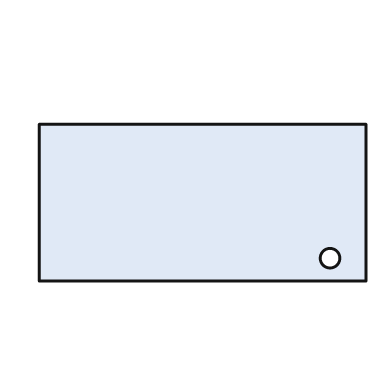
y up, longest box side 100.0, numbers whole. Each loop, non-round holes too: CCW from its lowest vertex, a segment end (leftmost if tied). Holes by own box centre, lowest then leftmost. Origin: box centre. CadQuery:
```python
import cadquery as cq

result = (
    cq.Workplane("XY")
    .moveTo(-50.0, -24.0)
    .lineTo(50.0, -24.0)
    .lineTo(50.0, 24.0)
    .lineTo(-50.0, 24.0)
    .close()
    .moveTo(39.0, -17.0)
    .circle(3.0)
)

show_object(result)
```